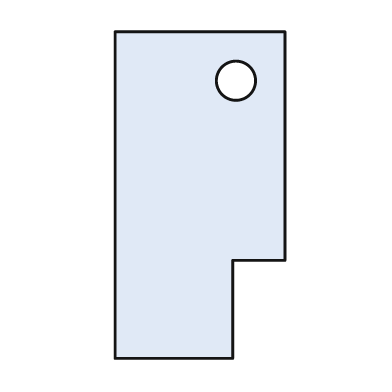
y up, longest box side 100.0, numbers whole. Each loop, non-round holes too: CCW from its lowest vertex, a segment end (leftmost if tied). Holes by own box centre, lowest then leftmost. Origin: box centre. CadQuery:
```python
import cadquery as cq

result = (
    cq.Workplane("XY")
    .moveTo(-26.0, -50.0)
    .lineTo(10.0, -50.0)
    .lineTo(10.0, -20.0)
    .lineTo(26.0, -20.0)
    .lineTo(26.0, 50.0)
    .lineTo(-26.0, 50.0)
    .close()
    .moveTo(11.0, 35.0)
    .circle(6.0)
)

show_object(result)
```